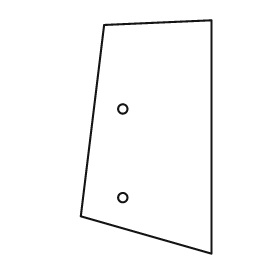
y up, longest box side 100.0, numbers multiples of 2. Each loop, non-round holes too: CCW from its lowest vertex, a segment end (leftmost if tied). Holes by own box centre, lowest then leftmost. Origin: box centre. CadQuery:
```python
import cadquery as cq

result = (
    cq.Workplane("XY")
    .moveTo(28.0, -50.0)
    .lineTo(28.0, 50.0)
    .lineTo(-18.0, 48.0)
    .lineTo(-28.0, -34.0)
    .close()
    .moveTo(-10.0, -26.0)
    .circle(2.0)
    .moveTo(-10.0, 12.0)
    .circle(2.0)
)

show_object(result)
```